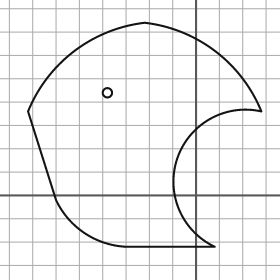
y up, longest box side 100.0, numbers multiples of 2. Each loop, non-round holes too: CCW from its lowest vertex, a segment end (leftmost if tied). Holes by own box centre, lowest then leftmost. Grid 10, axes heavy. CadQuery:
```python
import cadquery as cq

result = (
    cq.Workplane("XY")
    .moveTo(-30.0, -22.0)
    .lineTo(8.0, -22.0)
    .threePointArc((-8.0, 16.0), (28.0, 36.0))
    .threePointArc((8.0, 62.0), (-22.0, 74.0))
    .threePointArc((-52.0, 62.0), (-72.0, 36.0))
    .lineTo(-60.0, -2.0)
    .threePointArc((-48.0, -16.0), (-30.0, -22.0))
    .close()
    .moveTo(-38.0, 44.0)
    .circle(2.0)
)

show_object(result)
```